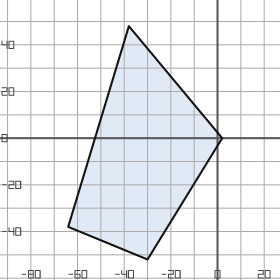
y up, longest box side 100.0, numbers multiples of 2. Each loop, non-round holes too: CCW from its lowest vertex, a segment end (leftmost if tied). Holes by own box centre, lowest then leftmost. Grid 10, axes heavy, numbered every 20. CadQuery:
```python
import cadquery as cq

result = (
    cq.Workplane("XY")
    .moveTo(-30.0, -52.0)
    .lineTo(2.0, 0.0)
    .lineTo(-38.0, 48.0)
    .lineTo(-64.0, -38.0)
    .close()
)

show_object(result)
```